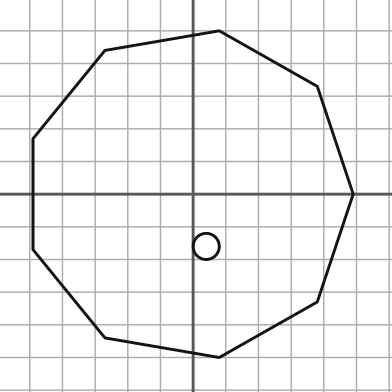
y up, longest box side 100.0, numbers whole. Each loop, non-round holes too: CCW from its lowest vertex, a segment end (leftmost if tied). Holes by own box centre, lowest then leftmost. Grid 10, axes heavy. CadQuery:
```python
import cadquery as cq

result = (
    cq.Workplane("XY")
    .moveTo(8.0, -50.0)
    .lineTo(38.0, -33.0)
    .lineTo(49.0, 0.0)
    .lineTo(38.0, 33.0)
    .lineTo(8.0, 50.0)
    .lineTo(-27.0, 44.0)
    .lineTo(-49.0, 17.0)
    .lineTo(-49.0, -17.0)
    .lineTo(-27.0, -44.0)
    .close()
    .moveTo(4.0, -16.0)
    .circle(4.0)
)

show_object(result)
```